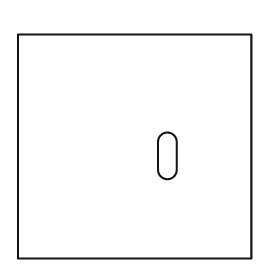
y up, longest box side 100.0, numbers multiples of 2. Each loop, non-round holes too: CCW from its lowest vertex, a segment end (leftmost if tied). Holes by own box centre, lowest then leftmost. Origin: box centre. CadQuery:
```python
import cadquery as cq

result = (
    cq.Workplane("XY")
    .moveTo(-50.0, -48.0)
    .lineTo(50.0, -48.0)
    .lineTo(50.0, 48.0)
    .lineTo(-50.0, 48.0)
    .close()
    .moveTo(10.0, -10.0)
    .threePointArc((14.0, -14.0), (18.0, -10.0))
    .lineTo(18.0, 2.0)
    .threePointArc((14.0, 6.0), (10.0, 2.0))
    .close()
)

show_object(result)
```